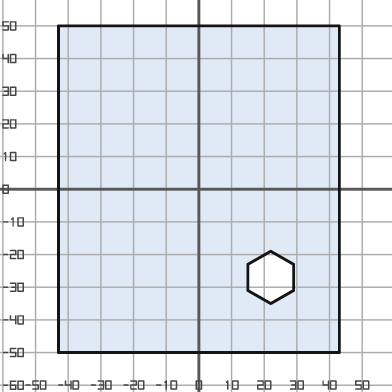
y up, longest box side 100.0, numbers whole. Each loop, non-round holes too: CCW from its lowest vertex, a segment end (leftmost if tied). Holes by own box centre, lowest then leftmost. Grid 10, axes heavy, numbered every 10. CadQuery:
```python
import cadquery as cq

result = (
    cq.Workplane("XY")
    .moveTo(-43.0, -50.0)
    .lineTo(43.0, -50.0)
    .lineTo(43.0, 50.0)
    .lineTo(-43.0, 50.0)
    .close()
    .moveTo(22.0, -35.0)
    .lineTo(29.0, -31.0)
    .lineTo(29.0, -23.0)
    .lineTo(22.0, -19.0)
    .lineTo(15.0, -23.0)
    .lineTo(15.0, -31.0)
    .close()
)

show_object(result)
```